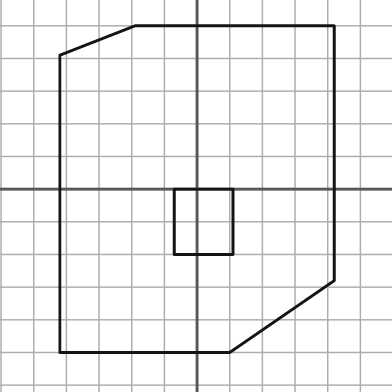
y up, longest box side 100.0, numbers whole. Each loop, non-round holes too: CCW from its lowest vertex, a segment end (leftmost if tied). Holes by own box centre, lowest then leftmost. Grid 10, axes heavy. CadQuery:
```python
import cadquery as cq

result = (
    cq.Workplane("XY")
    .moveTo(-42.0, -50.0)
    .lineTo(10.0, -50.0)
    .lineTo(42.0, -28.0)
    .lineTo(42.0, 50.0)
    .lineTo(-19.0, 50.0)
    .lineTo(-42.0, 41.0)
    .close()
    .moveTo(-7.0, -20.0)
    .lineTo(11.0, -20.0)
    .lineTo(11.0, 0.0)
    .lineTo(-7.0, 0.0)
    .close()
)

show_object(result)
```